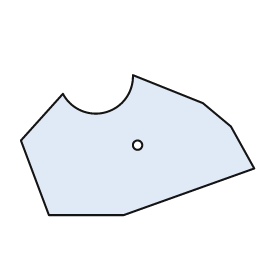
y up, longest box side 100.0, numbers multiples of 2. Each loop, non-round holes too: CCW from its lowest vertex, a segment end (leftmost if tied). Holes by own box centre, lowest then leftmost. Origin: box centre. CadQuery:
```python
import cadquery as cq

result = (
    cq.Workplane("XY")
    .moveTo(-38.0, -30.0)
    .lineTo(-6.0, -30.0)
    .lineTo(50.0, -10.0)
    .lineTo(40.0, 8.0)
    .lineTo(28.0, 18.0)
    .lineTo(-2.0, 30.0)
    .threePointArc((-14.0, 14.0), (-32.0, 22.0))
    .lineTo(-50.0, 2.0)
    .close()
    .moveTo(0.0, 0.0)
    .circle(2.0)
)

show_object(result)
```